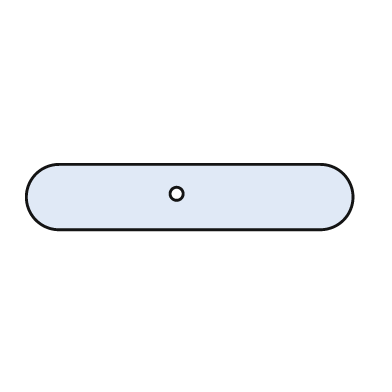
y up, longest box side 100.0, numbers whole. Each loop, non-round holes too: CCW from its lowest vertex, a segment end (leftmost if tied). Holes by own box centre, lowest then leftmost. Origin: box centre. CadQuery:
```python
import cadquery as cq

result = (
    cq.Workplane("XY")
    .moveTo(-40.0, -10.0)
    .lineTo(40.0, -10.0)
    .threePointArc((50.0, 0.0), (40.0, 10.0))
    .lineTo(-40.0, 10.0)
    .threePointArc((-50.0, 0.0), (-40.0, -10.0))
    .close()
    .moveTo(-4.0, 1.0)
    .circle(2.0)
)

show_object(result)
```